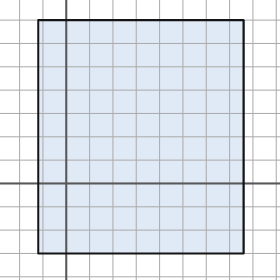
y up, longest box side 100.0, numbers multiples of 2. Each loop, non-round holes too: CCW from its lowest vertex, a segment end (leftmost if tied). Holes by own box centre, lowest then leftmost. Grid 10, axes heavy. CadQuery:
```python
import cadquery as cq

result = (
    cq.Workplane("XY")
    .moveTo(-12.0, -30.0)
    .lineTo(76.0, -30.0)
    .lineTo(76.0, 70.0)
    .lineTo(-12.0, 70.0)
    .close()
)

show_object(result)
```